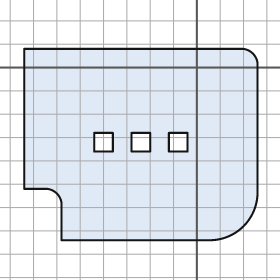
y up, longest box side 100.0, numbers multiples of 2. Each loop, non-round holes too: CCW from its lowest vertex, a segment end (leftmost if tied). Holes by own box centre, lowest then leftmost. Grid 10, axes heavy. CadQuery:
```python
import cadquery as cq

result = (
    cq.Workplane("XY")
    .moveTo(-58.0, -74.0)
    .lineTo(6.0, -74.0)
    .threePointArc((20.0, -68.0), (26.0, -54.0))
    .lineTo(26.0, 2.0)
    .threePointArc((24.0, 6.0), (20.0, 8.0))
    .lineTo(-74.0, 8.0)
    .lineTo(-74.0, -52.0)
    .lineTo(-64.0, -52.0)
    .threePointArc((-60.0, -54.0), (-58.0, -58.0))
    .close()
    .moveTo(-44.0, -36.0)
    .lineTo(-36.0, -36.0)
    .lineTo(-36.0, -28.0)
    .lineTo(-44.0, -28.0)
    .close()
    .moveTo(-28.0, -36.0)
    .lineTo(-20.0, -36.0)
    .lineTo(-20.0, -28.0)
    .lineTo(-28.0, -28.0)
    .close()
    .moveTo(-12.0, -36.0)
    .lineTo(-4.0, -36.0)
    .lineTo(-4.0, -28.0)
    .lineTo(-12.0, -28.0)
    .close()
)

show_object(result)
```